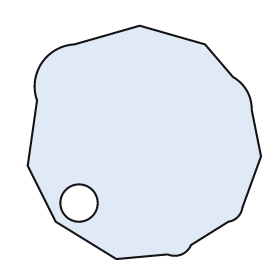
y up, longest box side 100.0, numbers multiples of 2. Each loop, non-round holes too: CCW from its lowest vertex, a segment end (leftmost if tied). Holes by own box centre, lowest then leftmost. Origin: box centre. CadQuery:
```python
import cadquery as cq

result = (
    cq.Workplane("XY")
    .moveTo(-12.0, -50.0)
    .lineTo(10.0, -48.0)
    .threePointArc((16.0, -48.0), (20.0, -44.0))
    .lineTo(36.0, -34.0)
    .threePointArc((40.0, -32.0), (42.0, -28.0))
    .lineTo(50.0, -6.0)
    .lineTo(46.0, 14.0)
    .threePointArc((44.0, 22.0), (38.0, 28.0))
    .lineTo(26.0, 42.0)
    .lineTo(-2.0, 50.0)
    .lineTo(-30.0, 42.0)
    .threePointArc((-44.0, 34.0), (-46.0, 18.0))
    .lineTo(-50.0, -10.0)
    .lineTo(-38.0, -34.0)
    .close()
    .moveTo(-28.0, -26.0)
    .circle(8.0)
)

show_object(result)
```